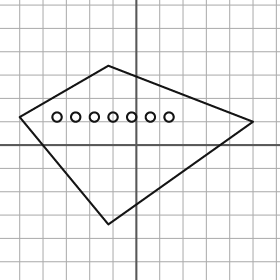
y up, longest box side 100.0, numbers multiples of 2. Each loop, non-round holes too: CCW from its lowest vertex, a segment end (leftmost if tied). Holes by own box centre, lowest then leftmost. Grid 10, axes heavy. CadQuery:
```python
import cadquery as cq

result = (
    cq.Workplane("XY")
    .moveTo(-12.0, -34.0)
    .lineTo(50.0, 10.0)
    .lineTo(-12.0, 34.0)
    .lineTo(-50.0, 12.0)
    .close()
    .moveTo(-34.0, 12.0)
    .circle(2.0)
    .moveTo(-26.0, 12.0)
    .circle(2.0)
    .moveTo(-18.0, 12.0)
    .circle(2.0)
    .moveTo(-10.0, 12.0)
    .circle(2.0)
    .moveTo(-2.0, 12.0)
    .circle(2.0)
    .moveTo(6.0, 12.0)
    .circle(2.0)
    .moveTo(14.0, 12.0)
    .circle(2.0)
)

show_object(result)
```